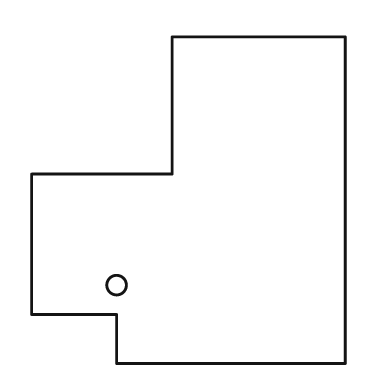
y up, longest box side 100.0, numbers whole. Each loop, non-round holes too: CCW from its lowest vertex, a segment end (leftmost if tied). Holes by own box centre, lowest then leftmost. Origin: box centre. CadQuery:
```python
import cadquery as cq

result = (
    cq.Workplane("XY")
    .moveTo(-22.0, -50.0)
    .lineTo(48.0, -50.0)
    .lineTo(48.0, 50.0)
    .lineTo(-5.0, 50.0)
    .lineTo(-5.0, 8.0)
    .lineTo(-48.0, 8.0)
    .lineTo(-48.0, -35.0)
    .lineTo(-22.0, -35.0)
    .close()
    .moveTo(-22.0, -26.0)
    .circle(3.0)
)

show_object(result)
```